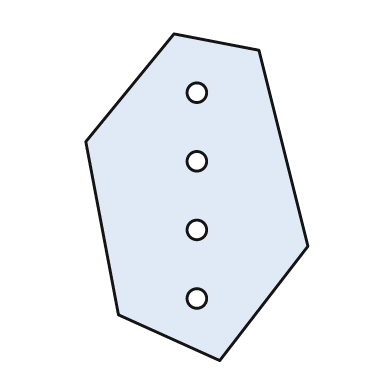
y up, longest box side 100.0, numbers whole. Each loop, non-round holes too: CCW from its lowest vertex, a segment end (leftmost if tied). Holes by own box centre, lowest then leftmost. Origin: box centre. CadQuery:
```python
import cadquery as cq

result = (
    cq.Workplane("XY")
    .moveTo(7.0, -50.0)
    .lineTo(34.0, -15.0)
    .lineTo(19.0, 45.0)
    .lineTo(-7.0, 50.0)
    .lineTo(-34.0, 17.0)
    .lineTo(-24.0, -36.0)
    .close()
    .moveTo(0.0, -31.0)
    .circle(3.0)
    .moveTo(0.0, -10.0)
    .circle(3.0)
    .moveTo(0.0, 11.0)
    .circle(3.0)
    .moveTo(0.0, 32.0)
    .circle(3.0)
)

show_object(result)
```